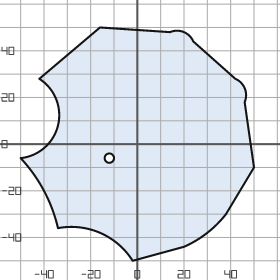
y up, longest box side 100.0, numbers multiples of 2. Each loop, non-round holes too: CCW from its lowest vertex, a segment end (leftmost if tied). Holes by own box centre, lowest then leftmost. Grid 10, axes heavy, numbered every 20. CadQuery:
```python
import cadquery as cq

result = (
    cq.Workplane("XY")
    .moveTo(-2.0, -50.0)
    .lineTo(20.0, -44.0)
    .threePointArc((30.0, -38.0), (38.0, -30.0))
    .lineTo(50.0, -10.0)
    .lineTo(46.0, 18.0)
    .threePointArc((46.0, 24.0), (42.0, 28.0))
    .lineTo(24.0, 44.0)
    .threePointArc((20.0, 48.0), (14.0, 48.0))
    .lineTo(-16.0, 50.0)
    .lineTo(-42.0, 28.0)
    .threePointArc((-34.0, 8.0), (-50.0, -6.0))
    .threePointArc((-40.0, -20.0), (-34.0, -36.0))
    .threePointArc((-16.0, -38.0), (-2.0, -50.0))
    .close()
    .moveTo(-12.0, -6.0)
    .circle(2.0)
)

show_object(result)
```